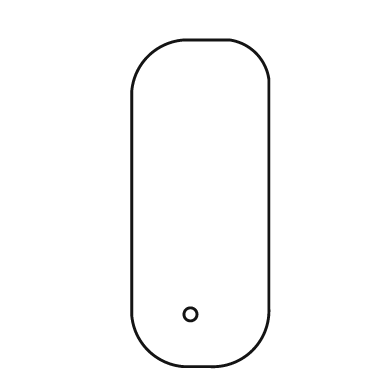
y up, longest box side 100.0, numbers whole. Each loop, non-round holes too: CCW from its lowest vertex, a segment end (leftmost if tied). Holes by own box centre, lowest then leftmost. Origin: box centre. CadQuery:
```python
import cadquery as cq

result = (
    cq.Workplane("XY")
    .moveTo(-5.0, -50.0)
    .lineTo(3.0, -50.0)
    .threePointArc((16.0, -45.0), (21.0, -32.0))
    .lineTo(21.0, 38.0)
    .threePointArc((17.0, 46.0), (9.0, 50.0))
    .lineTo(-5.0, 50.0)
    .threePointArc((-16.0, 45.0), (-21.0, 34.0))
    .lineTo(-21.0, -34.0)
    .threePointArc((-16.0, -45.0), (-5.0, -50.0))
    .close()
    .moveTo(-3.0, -34.0)
    .circle(2.0)
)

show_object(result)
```